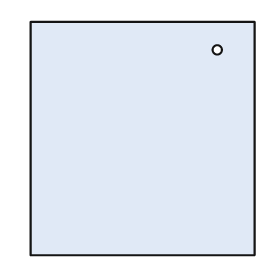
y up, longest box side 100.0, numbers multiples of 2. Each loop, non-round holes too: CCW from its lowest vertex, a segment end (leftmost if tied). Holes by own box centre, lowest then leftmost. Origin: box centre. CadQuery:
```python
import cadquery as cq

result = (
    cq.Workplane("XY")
    .moveTo(-48.0, -50.0)
    .lineTo(48.0, -50.0)
    .lineTo(48.0, 50.0)
    .lineTo(-48.0, 50.0)
    .close()
    .moveTo(32.0, 38.0)
    .circle(2.0)
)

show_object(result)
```